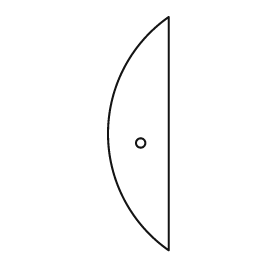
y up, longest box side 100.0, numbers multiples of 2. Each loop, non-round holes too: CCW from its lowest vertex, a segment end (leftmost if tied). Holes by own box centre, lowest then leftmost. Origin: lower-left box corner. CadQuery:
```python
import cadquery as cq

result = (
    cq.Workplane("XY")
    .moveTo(26.0, 0.0)
    .lineTo(26.0, 100.0)
    .threePointArc((0.0, 50.0), (26.0, 0.0))
    .close()
    .moveTo(14.0, 46.0)
    .circle(2.0)
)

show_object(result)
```